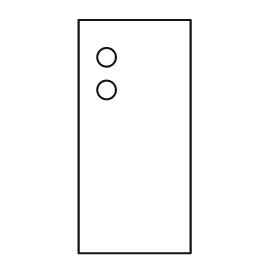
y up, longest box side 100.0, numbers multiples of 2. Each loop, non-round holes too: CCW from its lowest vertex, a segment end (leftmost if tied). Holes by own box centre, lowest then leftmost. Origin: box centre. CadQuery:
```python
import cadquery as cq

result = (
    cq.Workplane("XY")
    .moveTo(-24.0, -50.0)
    .lineTo(24.0, -50.0)
    .lineTo(24.0, 50.0)
    .lineTo(-24.0, 50.0)
    .close()
    .moveTo(-12.0, 20.0)
    .circle(4.0)
    .moveTo(-12.0, 34.0)
    .circle(4.0)
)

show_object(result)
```